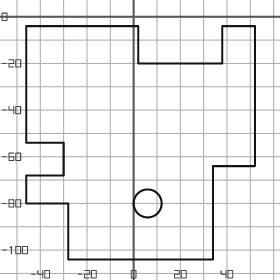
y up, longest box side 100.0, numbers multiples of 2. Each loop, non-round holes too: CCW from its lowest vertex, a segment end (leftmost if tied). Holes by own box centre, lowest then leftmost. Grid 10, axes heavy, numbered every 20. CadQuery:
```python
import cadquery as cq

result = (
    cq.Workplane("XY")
    .moveTo(-28.0, -104.0)
    .lineTo(34.0, -104.0)
    .lineTo(34.0, -64.0)
    .lineTo(52.0, -64.0)
    .lineTo(52.0, -4.0)
    .lineTo(38.0, -4.0)
    .lineTo(38.0, -20.0)
    .lineTo(2.0, -20.0)
    .lineTo(2.0, -4.0)
    .lineTo(-46.0, -4.0)
    .lineTo(-46.0, -54.0)
    .lineTo(-30.0, -54.0)
    .lineTo(-30.0, -68.0)
    .lineTo(-46.0, -68.0)
    .lineTo(-46.0, -80.0)
    .lineTo(-28.0, -80.0)
    .close()
    .moveTo(6.0, -80.0)
    .circle(6.0)
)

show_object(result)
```